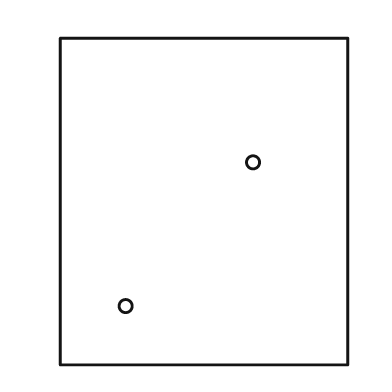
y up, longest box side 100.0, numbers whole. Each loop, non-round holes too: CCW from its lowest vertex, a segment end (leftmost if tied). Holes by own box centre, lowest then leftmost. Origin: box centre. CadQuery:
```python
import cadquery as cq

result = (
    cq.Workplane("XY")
    .moveTo(-44.0, -50.0)
    .lineTo(44.0, -50.0)
    .lineTo(44.0, 50.0)
    .lineTo(-44.0, 50.0)
    .close()
    .moveTo(-24.0, -32.0)
    .circle(2.0)
    .moveTo(15.0, 12.0)
    .circle(2.0)
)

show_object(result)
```